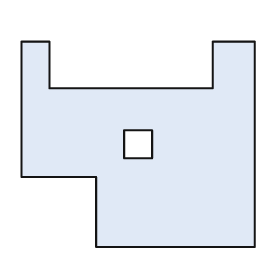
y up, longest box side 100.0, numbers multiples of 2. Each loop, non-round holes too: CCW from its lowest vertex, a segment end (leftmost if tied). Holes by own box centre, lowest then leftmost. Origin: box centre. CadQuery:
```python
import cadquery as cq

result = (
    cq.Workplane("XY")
    .moveTo(-18.0, -44.0)
    .lineTo(50.0, -44.0)
    .lineTo(50.0, 44.0)
    .lineTo(32.0, 44.0)
    .lineTo(32.0, 24.0)
    .lineTo(-38.0, 24.0)
    .lineTo(-38.0, 44.0)
    .lineTo(-50.0, 44.0)
    .lineTo(-50.0, -14.0)
    .lineTo(-18.0, -14.0)
    .close()
    .moveTo(-6.0, -6.0)
    .lineTo(6.0, -6.0)
    .lineTo(6.0, 6.0)
    .lineTo(-6.0, 6.0)
    .close()
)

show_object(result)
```